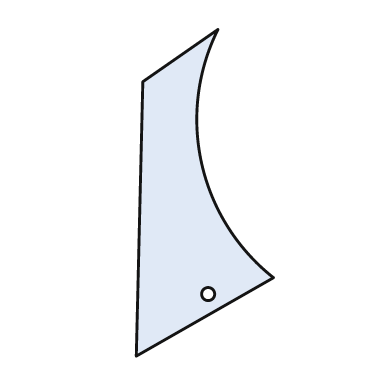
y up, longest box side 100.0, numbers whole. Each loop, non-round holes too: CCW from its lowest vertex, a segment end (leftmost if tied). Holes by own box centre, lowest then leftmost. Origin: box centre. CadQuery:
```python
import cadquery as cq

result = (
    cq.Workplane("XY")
    .moveTo(-21.0, -50.0)
    .lineTo(21.0, -26.0)
    .threePointArc((-1.0, 9.0), (4.0, 50.0))
    .lineTo(-19.0, 34.0)
    .close()
    .moveTo(1.0, -31.0)
    .circle(2.0)
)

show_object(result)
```